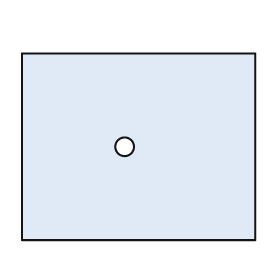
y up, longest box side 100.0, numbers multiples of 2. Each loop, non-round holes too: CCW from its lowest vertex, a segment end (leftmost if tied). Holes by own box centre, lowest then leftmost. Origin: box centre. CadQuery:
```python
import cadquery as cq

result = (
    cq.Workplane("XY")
    .moveTo(-50.0, -40.0)
    .lineTo(50.0, -40.0)
    .lineTo(50.0, 40.0)
    .lineTo(-50.0, 40.0)
    .close()
    .moveTo(-6.0, 0.0)
    .circle(4.0)
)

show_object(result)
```